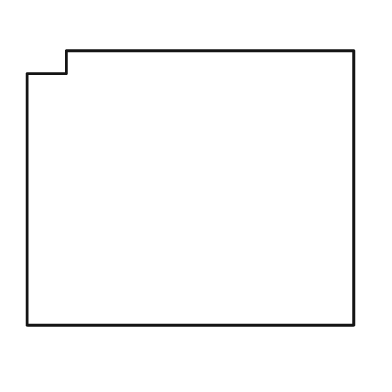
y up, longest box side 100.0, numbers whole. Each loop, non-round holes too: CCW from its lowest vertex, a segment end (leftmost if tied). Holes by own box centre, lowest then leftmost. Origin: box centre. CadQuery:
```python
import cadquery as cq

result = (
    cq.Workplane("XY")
    .moveTo(-50.0, -42.0)
    .lineTo(50.0, -42.0)
    .lineTo(50.0, 42.0)
    .lineTo(-38.0, 42.0)
    .lineTo(-38.0, 35.0)
    .lineTo(-50.0, 35.0)
    .close()
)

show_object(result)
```